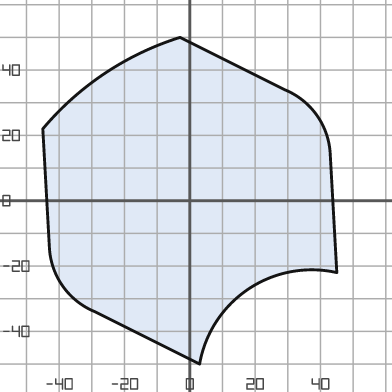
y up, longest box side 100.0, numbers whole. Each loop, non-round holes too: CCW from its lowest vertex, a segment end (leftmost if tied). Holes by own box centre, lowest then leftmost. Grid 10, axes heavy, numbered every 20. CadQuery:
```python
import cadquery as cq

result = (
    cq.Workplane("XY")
    .moveTo(3.0, -50.0)
    .threePointArc((18.0, -27.0), (45.0, -22.0))
    .lineTo(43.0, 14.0)
    .threePointArc((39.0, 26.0), (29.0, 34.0))
    .lineTo(-3.0, 50.0)
    .threePointArc((-26.0, 39.0), (-45.0, 22.0))
    .lineTo(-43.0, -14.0)
    .threePointArc((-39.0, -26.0), (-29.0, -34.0))
    .close()
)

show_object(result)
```